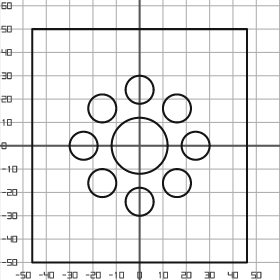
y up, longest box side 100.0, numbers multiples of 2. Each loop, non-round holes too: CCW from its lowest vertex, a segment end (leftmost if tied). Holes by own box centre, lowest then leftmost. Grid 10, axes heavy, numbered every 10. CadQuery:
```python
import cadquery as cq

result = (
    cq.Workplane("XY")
    .moveTo(-46.0, -50.0)
    .lineTo(46.0, -50.0)
    .lineTo(46.0, 50.0)
    .lineTo(-46.0, 50.0)
    .close()
    .moveTo(0.0, -24.0)
    .circle(6.0)
    .moveTo(-16.0, -16.0)
    .circle(6.0)
    .moveTo(16.0, -16.0)
    .circle(6.0)
    .moveTo(-24.0, 0.0)
    .circle(6.0)
    .moveTo(0.0, 0.0)
    .circle(12.0)
    .moveTo(24.0, 0.0)
    .circle(6.0)
    .moveTo(-16.0, 16.0)
    .circle(6.0)
    .moveTo(16.0, 16.0)
    .circle(6.0)
    .moveTo(0.0, 24.0)
    .circle(6.0)
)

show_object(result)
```